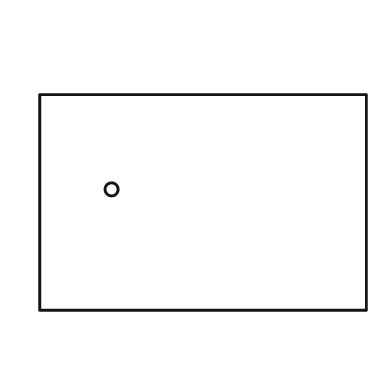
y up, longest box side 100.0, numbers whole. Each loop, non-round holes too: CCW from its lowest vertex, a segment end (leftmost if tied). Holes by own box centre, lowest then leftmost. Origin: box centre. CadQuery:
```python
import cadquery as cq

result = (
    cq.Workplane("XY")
    .moveTo(-50.0, -33.0)
    .lineTo(50.0, -33.0)
    .lineTo(50.0, 33.0)
    .lineTo(-50.0, 33.0)
    .close()
    .moveTo(-28.0, 4.0)
    .circle(2.0)
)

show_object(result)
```